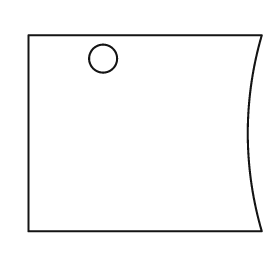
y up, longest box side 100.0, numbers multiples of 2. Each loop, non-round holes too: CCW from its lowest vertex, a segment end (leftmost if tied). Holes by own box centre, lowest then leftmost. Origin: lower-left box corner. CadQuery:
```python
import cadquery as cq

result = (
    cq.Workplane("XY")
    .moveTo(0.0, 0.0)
    .lineTo(100.0, 0.0)
    .threePointArc((94.0, 42.0), (100.0, 84.0))
    .lineTo(0.0, 84.0)
    .close()
    .moveTo(32.0, 74.0)
    .circle(6.0)
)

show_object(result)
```